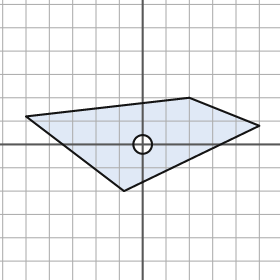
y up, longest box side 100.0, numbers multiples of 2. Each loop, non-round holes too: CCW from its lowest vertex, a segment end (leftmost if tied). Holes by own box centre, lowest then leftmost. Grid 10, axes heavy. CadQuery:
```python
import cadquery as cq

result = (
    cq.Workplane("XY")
    .moveTo(-8.0, -20.0)
    .lineTo(50.0, 8.0)
    .lineTo(20.0, 20.0)
    .lineTo(-50.0, 12.0)
    .close()
    .moveTo(0.0, 0.0)
    .circle(4.0)
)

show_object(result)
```